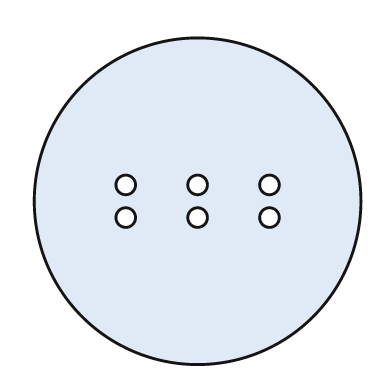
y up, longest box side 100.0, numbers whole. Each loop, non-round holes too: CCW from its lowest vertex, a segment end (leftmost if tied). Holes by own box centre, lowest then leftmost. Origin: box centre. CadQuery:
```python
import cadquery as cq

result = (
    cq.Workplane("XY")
    .moveTo(0.0, 0.0)
    .circle(50.0)
    .moveTo(-22.0, -5.0)
    .circle(3.0)
    .moveTo(0.0, -5.0)
    .circle(3.0)
    .moveTo(22.0, -5.0)
    .circle(3.0)
    .moveTo(-22.0, 5.0)
    .circle(3.0)
    .moveTo(0.0, 5.0)
    .circle(3.0)
    .moveTo(22.0, 5.0)
    .circle(3.0)
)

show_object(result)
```